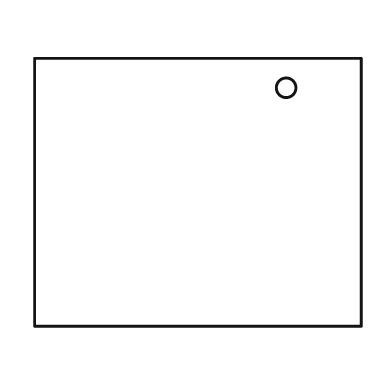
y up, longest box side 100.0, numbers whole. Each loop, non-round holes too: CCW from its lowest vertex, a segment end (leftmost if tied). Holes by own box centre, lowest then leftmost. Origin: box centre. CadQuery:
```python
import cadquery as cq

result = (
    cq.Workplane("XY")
    .moveTo(-50.0, -41.0)
    .lineTo(50.0, -41.0)
    .lineTo(50.0, 41.0)
    .lineTo(-50.0, 41.0)
    .close()
    .moveTo(27.0, 32.0)
    .circle(3.0)
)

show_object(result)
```